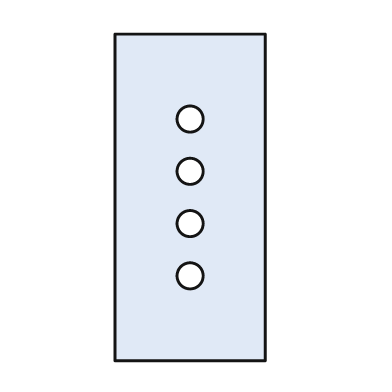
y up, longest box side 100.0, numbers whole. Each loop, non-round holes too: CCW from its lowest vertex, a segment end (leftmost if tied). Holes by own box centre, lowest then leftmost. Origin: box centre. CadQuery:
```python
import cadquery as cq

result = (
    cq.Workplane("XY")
    .moveTo(-23.0, -50.0)
    .lineTo(23.0, -50.0)
    .lineTo(23.0, 50.0)
    .lineTo(-23.0, 50.0)
    .close()
    .moveTo(0.0, -24.0)
    .circle(4.0)
    .moveTo(0.0, -8.0)
    .circle(4.0)
    .moveTo(0.0, 8.0)
    .circle(4.0)
    .moveTo(0.0, 24.0)
    .circle(4.0)
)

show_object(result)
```